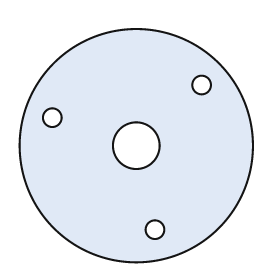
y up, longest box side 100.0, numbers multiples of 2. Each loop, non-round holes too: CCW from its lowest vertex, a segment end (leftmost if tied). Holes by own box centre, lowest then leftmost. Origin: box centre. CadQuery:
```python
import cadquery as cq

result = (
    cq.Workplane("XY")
    .moveTo(0.0, 0.0)
    .circle(50.0)
    .moveTo(8.0, -36.0)
    .circle(4.0)
    .moveTo(0.0, 0.0)
    .circle(10.0)
    .moveTo(-36.0, 12.0)
    .circle(4.0)
    .moveTo(28.0, 26.0)
    .circle(4.0)
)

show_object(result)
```